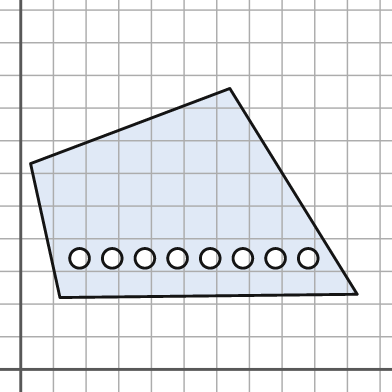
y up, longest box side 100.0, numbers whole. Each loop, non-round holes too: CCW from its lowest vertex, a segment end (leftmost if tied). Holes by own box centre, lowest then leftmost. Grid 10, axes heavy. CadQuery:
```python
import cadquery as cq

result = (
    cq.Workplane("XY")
    .moveTo(12.0, 22.0)
    .lineTo(103.0, 23.0)
    .lineTo(64.0, 86.0)
    .lineTo(3.0, 63.0)
    .close()
    .moveTo(18.0, 34.0)
    .circle(3.0)
    .moveTo(28.0, 34.0)
    .circle(3.0)
    .moveTo(38.0, 34.0)
    .circle(3.0)
    .moveTo(48.0, 34.0)
    .circle(3.0)
    .moveTo(58.0, 34.0)
    .circle(3.0)
    .moveTo(68.0, 34.0)
    .circle(3.0)
    .moveTo(78.0, 34.0)
    .circle(3.0)
    .moveTo(88.0, 34.0)
    .circle(3.0)
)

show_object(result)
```